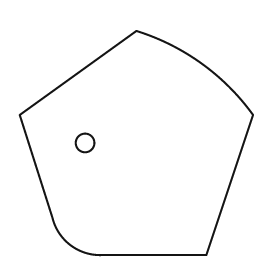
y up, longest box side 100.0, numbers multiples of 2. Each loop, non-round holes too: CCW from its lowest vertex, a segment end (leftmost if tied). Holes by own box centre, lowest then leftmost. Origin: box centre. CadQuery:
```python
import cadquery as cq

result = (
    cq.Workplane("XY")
    .moveTo(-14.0, -48.0)
    .lineTo(30.0, -48.0)
    .lineTo(50.0, 12.0)
    .threePointArc((28.0, 34.0), (0.0, 48.0))
    .lineTo(-50.0, 12.0)
    .lineTo(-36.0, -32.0)
    .threePointArc((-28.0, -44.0), (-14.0, -48.0))
    .close()
    .moveTo(-22.0, 0.0)
    .circle(4.0)
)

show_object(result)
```